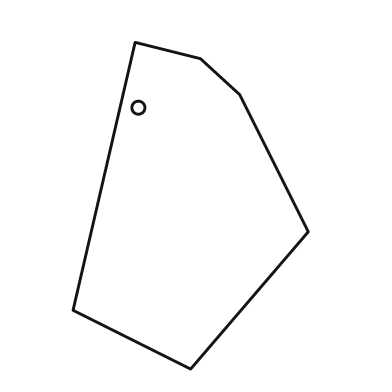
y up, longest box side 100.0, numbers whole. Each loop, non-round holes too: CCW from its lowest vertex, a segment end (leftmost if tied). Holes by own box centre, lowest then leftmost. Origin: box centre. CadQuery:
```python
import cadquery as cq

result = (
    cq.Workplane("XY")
    .moveTo(0.0, -50.0)
    .lineTo(36.0, -8.0)
    .lineTo(15.0, 34.0)
    .lineTo(3.0, 45.0)
    .lineTo(-17.0, 50.0)
    .lineTo(-36.0, -32.0)
    .close()
    .moveTo(-16.0, 30.0)
    .circle(2.0)
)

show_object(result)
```